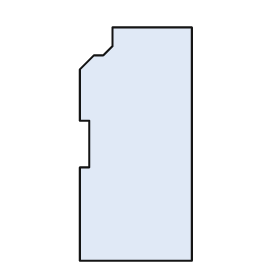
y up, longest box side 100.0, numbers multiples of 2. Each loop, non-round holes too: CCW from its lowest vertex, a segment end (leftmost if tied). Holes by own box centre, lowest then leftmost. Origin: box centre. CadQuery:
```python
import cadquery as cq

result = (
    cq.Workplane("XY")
    .moveTo(-24.0, -50.0)
    .lineTo(24.0, -50.0)
    .lineTo(24.0, 50.0)
    .lineTo(-10.0, 50.0)
    .lineTo(-10.0, 42.0)
    .lineTo(-14.0, 38.0)
    .lineTo(-18.0, 38.0)
    .lineTo(-24.0, 32.0)
    .lineTo(-24.0, 10.0)
    .lineTo(-20.0, 10.0)
    .lineTo(-20.0, -10.0)
    .lineTo(-24.0, -10.0)
    .close()
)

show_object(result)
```